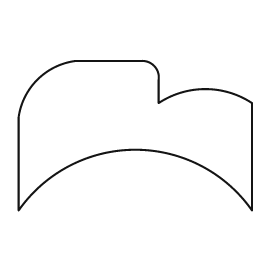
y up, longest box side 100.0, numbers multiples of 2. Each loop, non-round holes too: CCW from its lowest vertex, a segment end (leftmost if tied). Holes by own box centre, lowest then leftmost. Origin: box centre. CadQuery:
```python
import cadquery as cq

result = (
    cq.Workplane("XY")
    .moveTo(-50.0, -32.0)
    .threePointArc((0.0, -6.0), (50.0, -32.0))
    .lineTo(50.0, 14.0)
    .threePointArc((30.0, 20.0), (10.0, 14.0))
    .lineTo(10.0, 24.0)
    .threePointArc((8.0, 30.0), (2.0, 32.0))
    .lineTo(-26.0, 32.0)
    .threePointArc((-42.0, 24.0), (-50.0, 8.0))
    .close()
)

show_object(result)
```